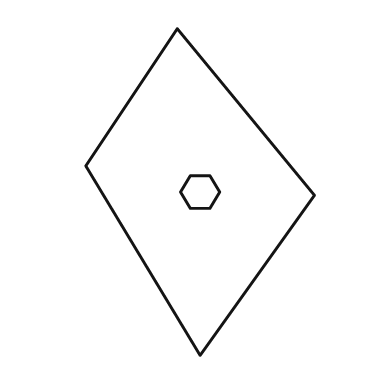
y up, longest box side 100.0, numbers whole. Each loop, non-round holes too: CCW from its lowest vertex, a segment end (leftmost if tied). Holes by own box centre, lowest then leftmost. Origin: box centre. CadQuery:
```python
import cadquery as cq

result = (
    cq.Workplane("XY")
    .moveTo(0.0, -50.0)
    .lineTo(35.0, -1.0)
    .lineTo(-7.0, 50.0)
    .lineTo(-35.0, 8.0)
    .close()
    .moveTo(-3.0, -5.0)
    .lineTo(3.0, -5.0)
    .lineTo(6.0, 0.0)
    .lineTo(3.0, 5.0)
    .lineTo(-3.0, 5.0)
    .lineTo(-6.0, 0.0)
    .close()
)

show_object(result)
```